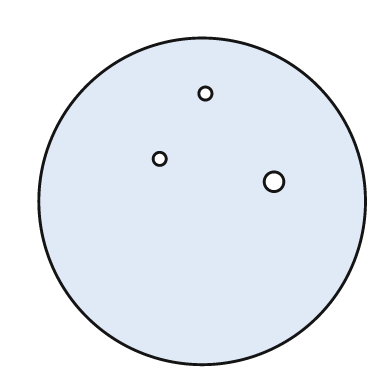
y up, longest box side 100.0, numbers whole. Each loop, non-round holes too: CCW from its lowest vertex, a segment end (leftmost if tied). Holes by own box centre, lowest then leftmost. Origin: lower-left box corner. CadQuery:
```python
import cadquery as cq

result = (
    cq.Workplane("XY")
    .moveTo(50.0, 50.0)
    .circle(50.0)
    .moveTo(72.0, 56.0)
    .circle(3.0)
    .moveTo(37.0, 63.0)
    .circle(2.0)
    .moveTo(51.0, 83.0)
    .circle(2.0)
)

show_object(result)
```